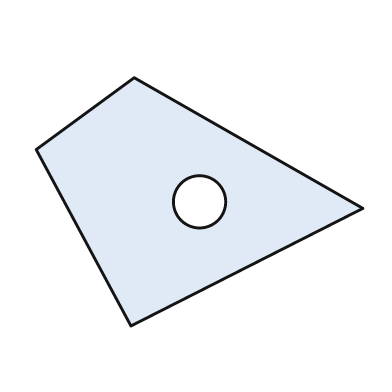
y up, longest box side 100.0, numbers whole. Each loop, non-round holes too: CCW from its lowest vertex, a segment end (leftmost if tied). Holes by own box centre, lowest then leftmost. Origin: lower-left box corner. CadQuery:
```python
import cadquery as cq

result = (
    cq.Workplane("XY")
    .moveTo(29.0, 0.0)
    .lineTo(100.0, 36.0)
    .lineTo(30.0, 76.0)
    .lineTo(0.0, 54.0)
    .close()
    .moveTo(50.0, 38.0)
    .circle(8.0)
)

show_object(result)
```